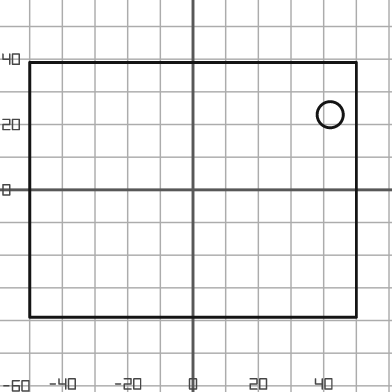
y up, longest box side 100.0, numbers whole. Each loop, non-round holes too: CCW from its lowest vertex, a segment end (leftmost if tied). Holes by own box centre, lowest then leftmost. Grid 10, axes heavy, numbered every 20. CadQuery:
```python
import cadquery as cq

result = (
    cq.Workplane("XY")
    .moveTo(-50.0, -39.0)
    .lineTo(50.0, -39.0)
    .lineTo(50.0, 39.0)
    .lineTo(-50.0, 39.0)
    .close()
    .moveTo(42.0, 23.0)
    .circle(4.0)
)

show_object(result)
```